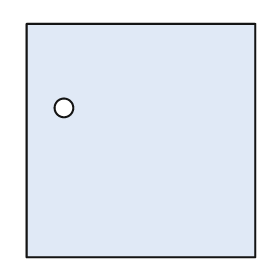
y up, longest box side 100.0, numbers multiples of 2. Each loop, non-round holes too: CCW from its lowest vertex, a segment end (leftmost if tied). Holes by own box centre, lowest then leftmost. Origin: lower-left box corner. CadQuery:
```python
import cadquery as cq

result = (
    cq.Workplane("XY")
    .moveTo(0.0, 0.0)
    .lineTo(98.0, 0.0)
    .lineTo(98.0, 100.0)
    .lineTo(0.0, 100.0)
    .close()
    .moveTo(16.0, 64.0)
    .circle(4.0)
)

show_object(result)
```